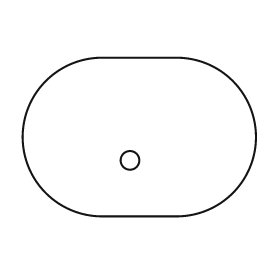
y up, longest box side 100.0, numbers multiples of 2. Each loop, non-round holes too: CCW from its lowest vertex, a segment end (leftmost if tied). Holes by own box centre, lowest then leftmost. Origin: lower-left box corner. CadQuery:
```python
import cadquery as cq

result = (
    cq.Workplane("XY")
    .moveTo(34.0, 0.0)
    .lineTo(66.0, 0.0)
    .threePointArc((100.0, 34.0), (66.0, 68.0))
    .lineTo(34.0, 68.0)
    .threePointArc((0.0, 34.0), (34.0, 0.0))
    .close()
    .moveTo(46.0, 24.0)
    .circle(4.0)
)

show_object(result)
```